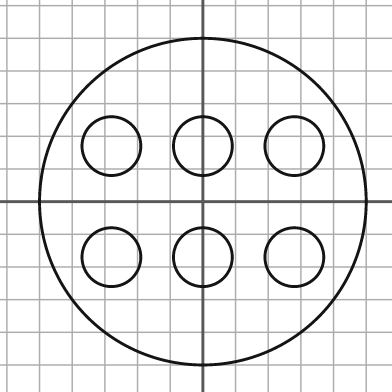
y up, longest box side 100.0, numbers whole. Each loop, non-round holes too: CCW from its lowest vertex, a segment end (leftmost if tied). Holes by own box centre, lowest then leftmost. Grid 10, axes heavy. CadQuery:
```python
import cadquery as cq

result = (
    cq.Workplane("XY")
    .moveTo(0.0, 0.0)
    .circle(50.0)
    .moveTo(-28.0, -17.0)
    .circle(9.0)
    .moveTo(0.0, -17.0)
    .circle(9.0)
    .moveTo(28.0, -17.0)
    .circle(9.0)
    .moveTo(-28.0, 17.0)
    .circle(9.0)
    .moveTo(0.0, 17.0)
    .circle(9.0)
    .moveTo(28.0, 17.0)
    .circle(9.0)
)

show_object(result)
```